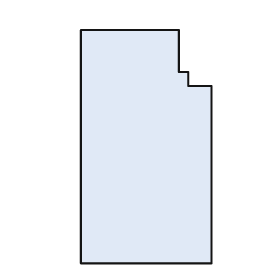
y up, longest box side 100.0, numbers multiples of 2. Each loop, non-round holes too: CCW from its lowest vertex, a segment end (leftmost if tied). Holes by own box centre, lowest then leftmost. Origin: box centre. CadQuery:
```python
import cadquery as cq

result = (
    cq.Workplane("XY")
    .moveTo(-28.0, -50.0)
    .lineTo(28.0, -50.0)
    .lineTo(28.0, 26.0)
    .lineTo(18.0, 26.0)
    .lineTo(18.0, 32.0)
    .lineTo(14.0, 32.0)
    .lineTo(14.0, 50.0)
    .lineTo(-28.0, 50.0)
    .close()
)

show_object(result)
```